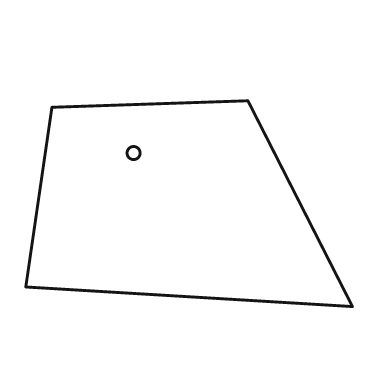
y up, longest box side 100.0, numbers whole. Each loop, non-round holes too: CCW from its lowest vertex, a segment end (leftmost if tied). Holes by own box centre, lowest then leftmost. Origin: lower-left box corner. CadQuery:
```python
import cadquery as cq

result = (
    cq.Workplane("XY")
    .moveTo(100.0, 0.0)
    .lineTo(68.0, 63.0)
    .lineTo(8.0, 61.0)
    .lineTo(0.0, 6.0)
    .close()
    .moveTo(33.0, 47.0)
    .circle(2.0)
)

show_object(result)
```